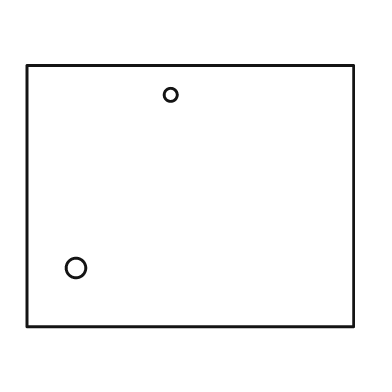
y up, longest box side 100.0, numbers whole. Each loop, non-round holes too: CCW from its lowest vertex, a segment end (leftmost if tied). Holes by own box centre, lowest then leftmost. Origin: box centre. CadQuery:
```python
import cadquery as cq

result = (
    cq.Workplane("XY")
    .moveTo(-50.0, -40.0)
    .lineTo(50.0, -40.0)
    .lineTo(50.0, 40.0)
    .lineTo(-50.0, 40.0)
    .close()
    .moveTo(-35.0, -22.0)
    .circle(3.0)
    .moveTo(-6.0, 31.0)
    .circle(2.0)
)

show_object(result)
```